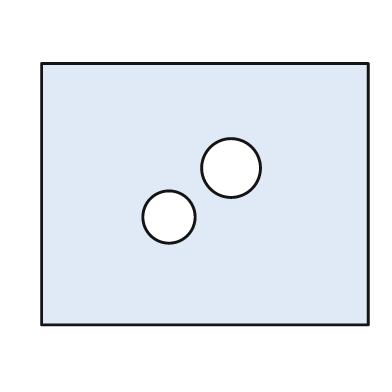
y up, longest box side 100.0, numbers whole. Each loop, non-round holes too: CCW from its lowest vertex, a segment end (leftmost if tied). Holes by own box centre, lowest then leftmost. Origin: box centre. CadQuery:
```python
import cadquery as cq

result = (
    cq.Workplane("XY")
    .moveTo(-50.0, -40.0)
    .lineTo(50.0, -40.0)
    .lineTo(50.0, 40.0)
    .lineTo(-50.0, 40.0)
    .close()
    .moveTo(-11.0, -7.0)
    .circle(8.0)
    .moveTo(8.0, 8.0)
    .circle(9.0)
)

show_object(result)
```